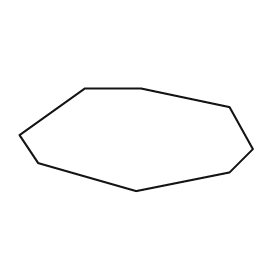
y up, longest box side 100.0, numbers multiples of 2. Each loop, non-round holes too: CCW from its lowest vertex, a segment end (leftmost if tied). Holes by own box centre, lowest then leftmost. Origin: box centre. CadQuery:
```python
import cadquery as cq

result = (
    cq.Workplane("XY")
    .moveTo(0.0, -22.0)
    .lineTo(40.0, -14.0)
    .lineTo(50.0, -4.0)
    .lineTo(40.0, 14.0)
    .lineTo(2.0, 22.0)
    .lineTo(-22.0, 22.0)
    .lineTo(-50.0, 2.0)
    .lineTo(-42.0, -10.0)
    .close()
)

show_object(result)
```